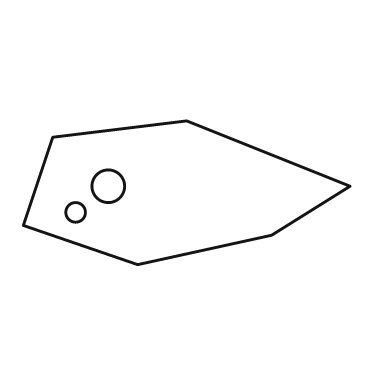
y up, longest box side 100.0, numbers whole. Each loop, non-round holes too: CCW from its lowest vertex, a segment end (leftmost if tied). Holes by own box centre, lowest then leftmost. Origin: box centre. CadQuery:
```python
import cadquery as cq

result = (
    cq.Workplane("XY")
    .moveTo(-15.0, -22.0)
    .lineTo(26.0, -13.0)
    .lineTo(50.0, 2.0)
    .lineTo(0.0, 22.0)
    .lineTo(-41.0, 17.0)
    .lineTo(-50.0, -10.0)
    .close()
    .moveTo(-34.0, -6.0)
    .circle(3.0)
    .moveTo(-24.0, 2.0)
    .circle(5.0)
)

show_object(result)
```